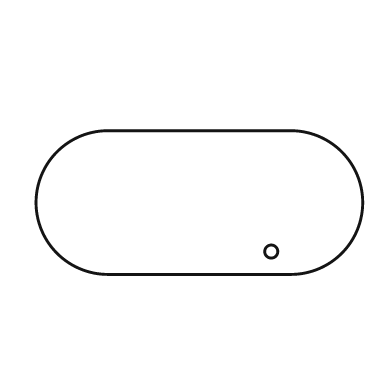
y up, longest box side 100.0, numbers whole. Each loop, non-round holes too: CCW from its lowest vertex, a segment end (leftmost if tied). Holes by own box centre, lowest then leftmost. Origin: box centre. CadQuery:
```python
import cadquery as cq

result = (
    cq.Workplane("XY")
    .moveTo(-28.0, -22.0)
    .lineTo(28.0, -22.0)
    .threePointArc((50.0, 0.0), (28.0, 22.0))
    .lineTo(-28.0, 22.0)
    .threePointArc((-50.0, 0.0), (-28.0, -22.0))
    .close()
    .moveTo(22.0, -15.0)
    .circle(2.0)
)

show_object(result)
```